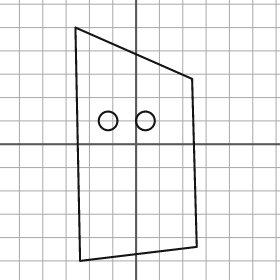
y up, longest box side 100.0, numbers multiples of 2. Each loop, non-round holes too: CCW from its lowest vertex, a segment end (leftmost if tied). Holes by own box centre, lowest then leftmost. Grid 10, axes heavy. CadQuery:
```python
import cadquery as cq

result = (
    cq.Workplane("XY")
    .moveTo(-24.0, -50.0)
    .lineTo(26.0, -44.0)
    .lineTo(24.0, 28.0)
    .lineTo(-26.0, 50.0)
    .close()
    .moveTo(-12.0, 10.0)
    .circle(4.0)
    .moveTo(4.0, 10.0)
    .circle(4.0)
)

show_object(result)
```